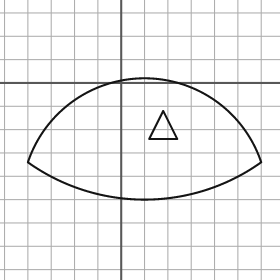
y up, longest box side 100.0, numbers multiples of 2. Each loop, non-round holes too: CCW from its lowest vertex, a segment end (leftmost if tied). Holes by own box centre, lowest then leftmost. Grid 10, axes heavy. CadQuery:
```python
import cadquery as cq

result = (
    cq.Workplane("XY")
    .moveTo(-40.0, -34.0)
    .threePointArc((10.0, -50.0), (60.0, -34.0))
    .threePointArc((10.0, 2.0), (-40.0, -34.0))
    .close()
    .moveTo(12.0, -24.0)
    .lineTo(24.0, -24.0)
    .lineTo(18.0, -12.0)
    .close()
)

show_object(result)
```